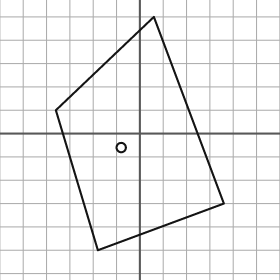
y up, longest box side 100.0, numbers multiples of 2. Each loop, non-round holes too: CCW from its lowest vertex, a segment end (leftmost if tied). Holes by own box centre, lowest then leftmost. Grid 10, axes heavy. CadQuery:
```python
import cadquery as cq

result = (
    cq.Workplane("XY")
    .moveTo(-18.0, -50.0)
    .lineTo(36.0, -30.0)
    .lineTo(6.0, 50.0)
    .lineTo(-36.0, 10.0)
    .close()
    .moveTo(-8.0, -6.0)
    .circle(2.0)
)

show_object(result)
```